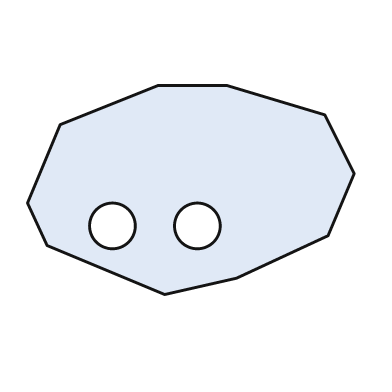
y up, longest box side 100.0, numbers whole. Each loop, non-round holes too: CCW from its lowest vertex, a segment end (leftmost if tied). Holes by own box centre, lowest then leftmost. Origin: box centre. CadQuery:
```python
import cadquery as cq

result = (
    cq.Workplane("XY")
    .moveTo(-8.0, -32.0)
    .lineTo(14.0, -27.0)
    .lineTo(42.0, -14.0)
    .lineTo(50.0, 5.0)
    .lineTo(41.0, 23.0)
    .lineTo(11.0, 32.0)
    .lineTo(-10.0, 32.0)
    .lineTo(-40.0, 20.0)
    .lineTo(-50.0, -4.0)
    .lineTo(-44.0, -17.0)
    .close()
    .moveTo(-24.0, -11.0)
    .circle(7.0)
    .moveTo(2.0, -11.0)
    .circle(7.0)
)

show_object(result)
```